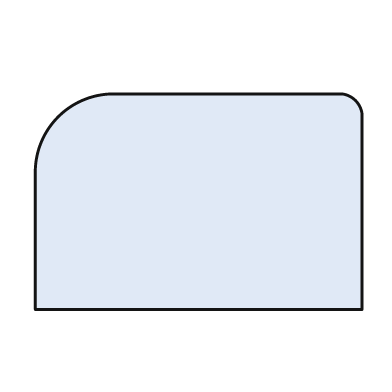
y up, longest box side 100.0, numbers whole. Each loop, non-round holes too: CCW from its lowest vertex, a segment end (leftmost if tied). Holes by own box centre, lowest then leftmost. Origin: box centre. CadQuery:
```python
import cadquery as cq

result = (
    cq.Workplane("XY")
    .moveTo(-50.0, -33.0)
    .lineTo(50.0, -33.0)
    .lineTo(50.0, 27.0)
    .threePointArc((48.0, 31.0), (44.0, 33.0))
    .lineTo(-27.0, 33.0)
    .threePointArc((-43.0, 26.0), (-50.0, 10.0))
    .close()
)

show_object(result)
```